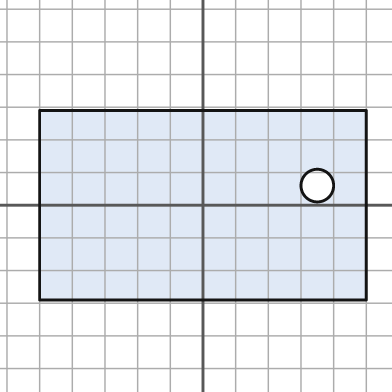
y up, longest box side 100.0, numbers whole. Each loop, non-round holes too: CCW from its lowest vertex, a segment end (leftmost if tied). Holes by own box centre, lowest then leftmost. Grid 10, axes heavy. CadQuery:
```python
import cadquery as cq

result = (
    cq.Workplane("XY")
    .moveTo(-50.0, -29.0)
    .lineTo(50.0, -29.0)
    .lineTo(50.0, 29.0)
    .lineTo(-50.0, 29.0)
    .close()
    .moveTo(35.0, 6.0)
    .circle(5.0)
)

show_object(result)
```